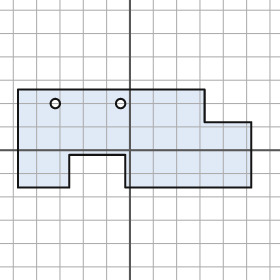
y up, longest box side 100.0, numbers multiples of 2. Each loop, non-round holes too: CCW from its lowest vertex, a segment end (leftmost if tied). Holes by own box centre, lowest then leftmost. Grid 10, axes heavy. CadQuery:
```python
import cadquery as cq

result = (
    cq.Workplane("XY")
    .moveTo(-48.0, -16.0)
    .lineTo(-26.0, -16.0)
    .lineTo(-26.0, -2.0)
    .lineTo(-2.0, -2.0)
    .lineTo(-2.0, -16.0)
    .lineTo(52.0, -16.0)
    .lineTo(52.0, 12.0)
    .lineTo(32.0, 12.0)
    .lineTo(32.0, 26.0)
    .lineTo(-48.0, 26.0)
    .close()
    .moveTo(-32.0, 20.0)
    .circle(2.0)
    .moveTo(-4.0, 20.0)
    .circle(2.0)
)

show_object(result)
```